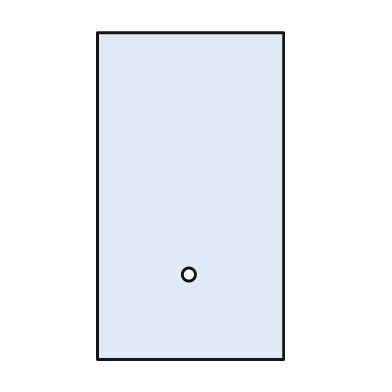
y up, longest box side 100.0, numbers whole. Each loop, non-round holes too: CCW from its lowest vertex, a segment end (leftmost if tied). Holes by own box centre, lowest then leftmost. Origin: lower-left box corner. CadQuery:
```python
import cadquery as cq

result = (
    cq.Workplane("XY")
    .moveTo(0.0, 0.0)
    .lineTo(57.0, 0.0)
    .lineTo(57.0, 100.0)
    .lineTo(0.0, 100.0)
    .close()
    .moveTo(28.0, 26.0)
    .circle(2.0)
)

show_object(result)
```